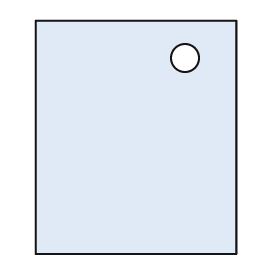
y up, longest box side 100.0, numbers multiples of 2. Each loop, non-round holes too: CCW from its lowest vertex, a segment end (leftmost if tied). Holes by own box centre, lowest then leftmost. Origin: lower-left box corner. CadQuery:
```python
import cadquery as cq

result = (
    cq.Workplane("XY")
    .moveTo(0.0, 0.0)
    .lineTo(86.0, 0.0)
    .lineTo(86.0, 100.0)
    .lineTo(0.0, 100.0)
    .close()
    .moveTo(64.0, 84.0)
    .circle(6.0)
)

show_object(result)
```